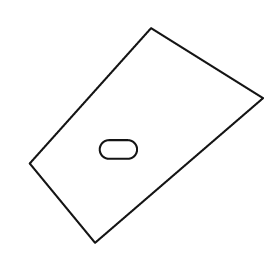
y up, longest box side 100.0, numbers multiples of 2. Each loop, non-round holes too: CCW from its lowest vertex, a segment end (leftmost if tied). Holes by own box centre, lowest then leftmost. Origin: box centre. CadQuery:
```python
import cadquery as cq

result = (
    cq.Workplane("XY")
    .moveTo(-22.0, -46.0)
    .lineTo(50.0, 16.0)
    .lineTo(2.0, 46.0)
    .lineTo(-50.0, -12.0)
    .close()
    .moveTo(-16.0, -10.0)
    .lineTo(-8.0, -10.0)
    .threePointArc((-4.0, -6.0), (-8.0, -2.0))
    .lineTo(-16.0, -2.0)
    .threePointArc((-20.0, -6.0), (-16.0, -10.0))
    .close()
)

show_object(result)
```